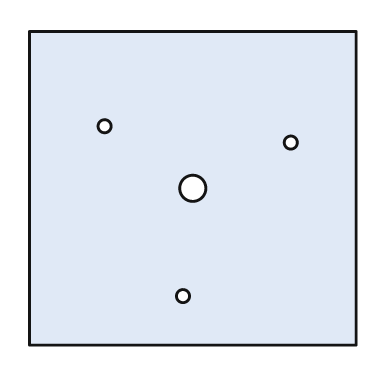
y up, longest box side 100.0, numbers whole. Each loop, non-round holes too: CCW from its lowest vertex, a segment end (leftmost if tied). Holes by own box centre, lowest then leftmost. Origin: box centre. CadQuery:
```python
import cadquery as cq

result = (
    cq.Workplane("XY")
    .moveTo(-50.0, -48.0)
    .lineTo(50.0, -48.0)
    .lineTo(50.0, 48.0)
    .lineTo(-50.0, 48.0)
    .close()
    .moveTo(-3.0, -33.0)
    .circle(2.0)
    .moveTo(0.0, 0.0)
    .circle(4.0)
    .moveTo(30.0, 14.0)
    .circle(2.0)
    .moveTo(-27.0, 19.0)
    .circle(2.0)
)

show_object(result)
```